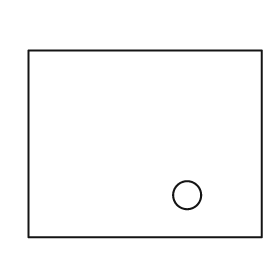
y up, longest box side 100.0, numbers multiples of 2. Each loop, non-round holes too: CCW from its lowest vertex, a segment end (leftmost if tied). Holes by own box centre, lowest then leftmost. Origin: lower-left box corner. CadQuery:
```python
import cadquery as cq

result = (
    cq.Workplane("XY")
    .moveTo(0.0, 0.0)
    .lineTo(100.0, 0.0)
    .lineTo(100.0, 80.0)
    .lineTo(0.0, 80.0)
    .close()
    .moveTo(68.0, 18.0)
    .circle(6.0)
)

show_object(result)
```